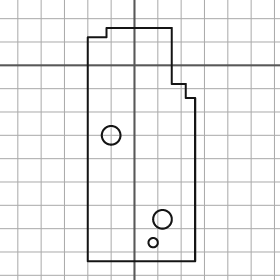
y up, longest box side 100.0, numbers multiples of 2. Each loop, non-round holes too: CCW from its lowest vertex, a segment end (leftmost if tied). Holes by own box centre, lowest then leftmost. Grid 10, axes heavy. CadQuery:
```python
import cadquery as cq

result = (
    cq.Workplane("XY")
    .moveTo(-20.0, -84.0)
    .lineTo(26.0, -84.0)
    .lineTo(26.0, -14.0)
    .lineTo(22.0, -14.0)
    .lineTo(22.0, -8.0)
    .lineTo(16.0, -8.0)
    .lineTo(16.0, 16.0)
    .lineTo(-12.0, 16.0)
    .lineTo(-12.0, 12.0)
    .lineTo(-20.0, 12.0)
    .close()
    .moveTo(8.0, -76.0)
    .circle(2.0)
    .moveTo(12.0, -66.0)
    .circle(4.0)
    .moveTo(-10.0, -30.0)
    .circle(4.0)
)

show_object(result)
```